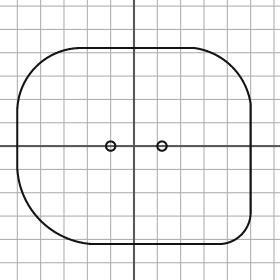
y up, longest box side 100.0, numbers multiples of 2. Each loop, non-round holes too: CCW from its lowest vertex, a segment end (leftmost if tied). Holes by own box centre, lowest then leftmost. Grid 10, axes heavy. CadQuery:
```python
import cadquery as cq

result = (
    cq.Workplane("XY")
    .moveTo(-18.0, -42.0)
    .lineTo(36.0, -42.0)
    .threePointArc((46.0, -38.0), (50.0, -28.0))
    .lineTo(50.0, 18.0)
    .threePointArc((42.0, 34.0), (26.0, 42.0))
    .lineTo(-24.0, 42.0)
    .threePointArc((-42.0, 34.0), (-50.0, 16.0))
    .lineTo(-50.0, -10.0)
    .threePointArc((-40.0, -32.0), (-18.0, -42.0))
    .close()
    .moveTo(-10.0, 0.0)
    .circle(2.0)
    .moveTo(12.0, 0.0)
    .circle(2.0)
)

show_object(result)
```